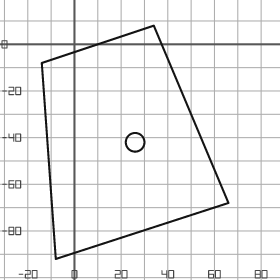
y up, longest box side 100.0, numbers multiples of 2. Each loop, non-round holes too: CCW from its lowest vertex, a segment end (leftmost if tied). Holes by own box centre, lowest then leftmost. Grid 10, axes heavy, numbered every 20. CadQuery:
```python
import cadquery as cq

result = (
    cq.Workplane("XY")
    .moveTo(-8.0, -92.0)
    .lineTo(66.0, -68.0)
    .lineTo(34.0, 8.0)
    .lineTo(-14.0, -8.0)
    .close()
    .moveTo(26.0, -42.0)
    .circle(4.0)
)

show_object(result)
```